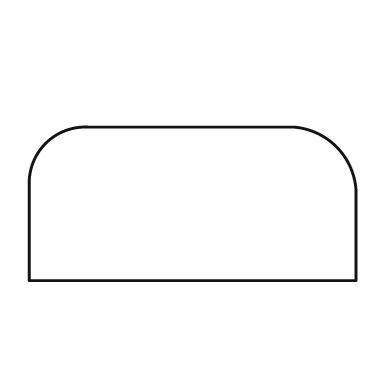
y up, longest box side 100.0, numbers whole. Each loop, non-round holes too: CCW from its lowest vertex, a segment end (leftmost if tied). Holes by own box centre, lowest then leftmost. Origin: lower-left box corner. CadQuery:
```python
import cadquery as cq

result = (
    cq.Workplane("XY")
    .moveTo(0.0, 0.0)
    .lineTo(100.0, 0.0)
    .lineTo(100.0, 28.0)
    .threePointArc((94.0, 41.0), (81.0, 47.0))
    .lineTo(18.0, 47.0)
    .threePointArc((5.0, 42.0), (0.0, 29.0))
    .close()
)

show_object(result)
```